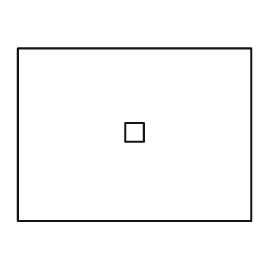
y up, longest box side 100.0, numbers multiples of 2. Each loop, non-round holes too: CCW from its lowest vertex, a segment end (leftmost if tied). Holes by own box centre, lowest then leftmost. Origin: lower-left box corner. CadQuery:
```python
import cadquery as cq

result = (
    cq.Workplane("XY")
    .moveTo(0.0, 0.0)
    .lineTo(100.0, 0.0)
    .lineTo(100.0, 74.0)
    .lineTo(0.0, 74.0)
    .close()
    .moveTo(46.0, 34.0)
    .lineTo(54.0, 34.0)
    .lineTo(54.0, 42.0)
    .lineTo(46.0, 42.0)
    .close()
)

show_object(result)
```